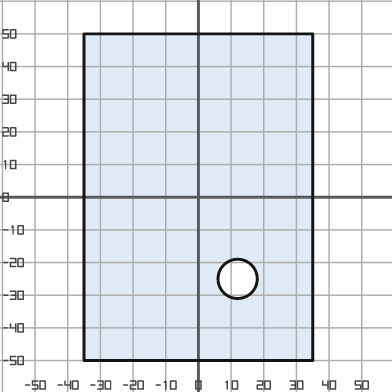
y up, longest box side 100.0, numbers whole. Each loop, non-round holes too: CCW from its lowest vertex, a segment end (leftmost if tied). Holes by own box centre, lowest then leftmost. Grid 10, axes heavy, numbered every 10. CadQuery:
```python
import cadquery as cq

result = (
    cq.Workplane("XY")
    .moveTo(-35.0, -50.0)
    .lineTo(35.0, -50.0)
    .lineTo(35.0, 50.0)
    .lineTo(-35.0, 50.0)
    .close()
    .moveTo(12.0, -25.0)
    .circle(6.0)
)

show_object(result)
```